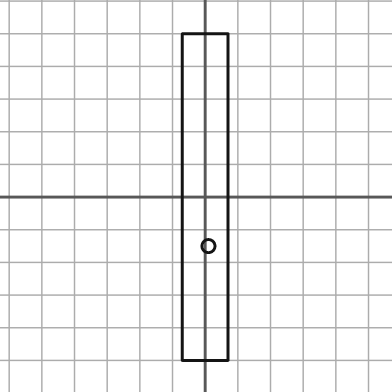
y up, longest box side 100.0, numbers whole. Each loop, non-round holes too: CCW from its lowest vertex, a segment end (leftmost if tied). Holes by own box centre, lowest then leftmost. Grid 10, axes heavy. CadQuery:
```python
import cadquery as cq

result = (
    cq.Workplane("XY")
    .moveTo(-7.0, -50.0)
    .lineTo(7.0, -50.0)
    .lineTo(7.0, 50.0)
    .lineTo(-7.0, 50.0)
    .close()
    .moveTo(1.0, -15.0)
    .circle(2.0)
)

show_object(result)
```